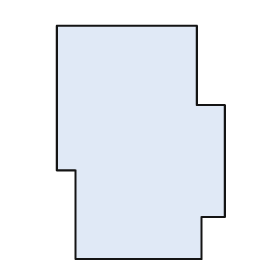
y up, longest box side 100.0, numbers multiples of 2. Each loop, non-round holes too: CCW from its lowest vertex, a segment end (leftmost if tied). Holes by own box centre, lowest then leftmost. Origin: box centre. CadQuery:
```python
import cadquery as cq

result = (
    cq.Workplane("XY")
    .moveTo(-28.0, -50.0)
    .lineTo(26.0, -50.0)
    .lineTo(26.0, -32.0)
    .lineTo(36.0, -32.0)
    .lineTo(36.0, 16.0)
    .lineTo(24.0, 16.0)
    .lineTo(24.0, 50.0)
    .lineTo(-36.0, 50.0)
    .lineTo(-36.0, -12.0)
    .lineTo(-28.0, -12.0)
    .close()
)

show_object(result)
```